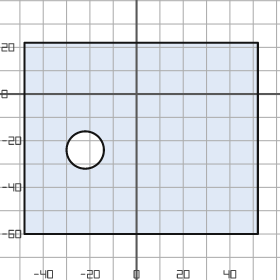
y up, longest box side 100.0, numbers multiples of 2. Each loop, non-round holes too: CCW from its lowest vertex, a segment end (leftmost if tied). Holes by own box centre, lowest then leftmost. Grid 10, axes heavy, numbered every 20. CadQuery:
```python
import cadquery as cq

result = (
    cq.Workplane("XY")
    .moveTo(-48.0, -60.0)
    .lineTo(52.0, -60.0)
    .lineTo(52.0, 22.0)
    .lineTo(-48.0, 22.0)
    .close()
    .moveTo(-22.0, -24.0)
    .circle(8.0)
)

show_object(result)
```